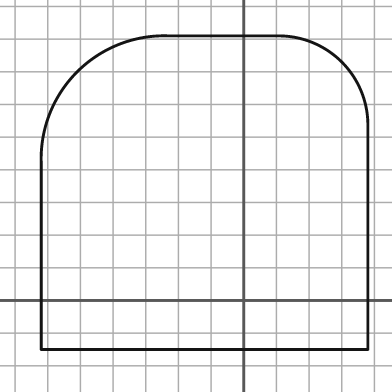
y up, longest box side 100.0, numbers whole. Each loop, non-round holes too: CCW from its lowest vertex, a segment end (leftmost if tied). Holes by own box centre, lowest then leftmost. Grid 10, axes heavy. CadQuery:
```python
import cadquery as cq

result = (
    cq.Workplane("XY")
    .moveTo(-62.0, -15.0)
    .lineTo(38.0, -15.0)
    .lineTo(38.0, 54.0)
    .threePointArc((30.0, 73.0), (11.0, 81.0))
    .lineTo(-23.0, 81.0)
    .threePointArc((-51.0, 70.0), (-62.0, 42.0))
    .close()
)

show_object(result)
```